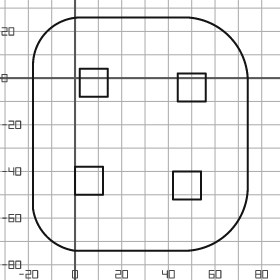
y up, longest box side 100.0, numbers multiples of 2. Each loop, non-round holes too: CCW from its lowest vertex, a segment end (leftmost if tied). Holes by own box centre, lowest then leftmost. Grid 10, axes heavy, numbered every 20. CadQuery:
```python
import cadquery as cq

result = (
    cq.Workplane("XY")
    .moveTo(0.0, -74.0)
    .lineTo(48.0, -74.0)
    .threePointArc((66.0, -66.0), (74.0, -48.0))
    .lineTo(74.0, 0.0)
    .threePointArc((66.0, 18.0), (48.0, 26.0))
    .lineTo(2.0, 26.0)
    .threePointArc((-12.0, 20.0), (-18.0, 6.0))
    .lineTo(-18.0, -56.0)
    .threePointArc((-12.0, -68.0), (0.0, -74.0))
    .close()
    .moveTo(42.0, -52.0)
    .lineTo(54.0, -52.0)
    .lineTo(54.0, -40.0)
    .lineTo(42.0, -40.0)
    .close()
    .moveTo(0.0, -50.0)
    .lineTo(12.0, -50.0)
    .lineTo(12.0, -38.0)
    .lineTo(0.0, -38.0)
    .close()
    .moveTo(44.0, -10.0)
    .lineTo(56.0, -10.0)
    .lineTo(56.0, 2.0)
    .lineTo(44.0, 2.0)
    .close()
    .moveTo(2.0, -8.0)
    .lineTo(14.0, -8.0)
    .lineTo(14.0, 4.0)
    .lineTo(2.0, 4.0)
    .close()
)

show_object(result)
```